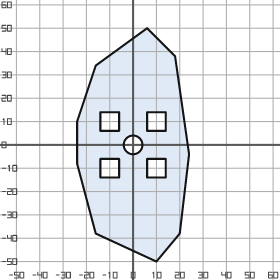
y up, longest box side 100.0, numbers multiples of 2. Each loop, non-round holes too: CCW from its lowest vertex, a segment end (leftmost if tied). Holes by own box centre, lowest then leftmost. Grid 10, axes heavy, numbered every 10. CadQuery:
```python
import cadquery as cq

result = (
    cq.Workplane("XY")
    .moveTo(10.0, -50.0)
    .lineTo(20.0, -38.0)
    .lineTo(24.0, -4.0)
    .lineTo(18.0, 38.0)
    .lineTo(6.0, 50.0)
    .lineTo(-16.0, 34.0)
    .lineTo(-24.0, 10.0)
    .lineTo(-24.0, -8.0)
    .lineTo(-16.0, -38.0)
    .close()
    .moveTo(-14.0, -14.0)
    .lineTo(-6.0, -14.0)
    .lineTo(-6.0, -6.0)
    .lineTo(-14.0, -6.0)
    .close()
    .moveTo(6.0, -14.0)
    .lineTo(14.0, -14.0)
    .lineTo(14.0, -6.0)
    .lineTo(6.0, -6.0)
    .close()
    .moveTo(0.0, 0.0)
    .circle(4.0)
    .moveTo(-14.0, 6.0)
    .lineTo(-6.0, 6.0)
    .lineTo(-6.0, 14.0)
    .lineTo(-14.0, 14.0)
    .close()
    .moveTo(6.0, 6.0)
    .lineTo(14.0, 6.0)
    .lineTo(14.0, 14.0)
    .lineTo(6.0, 14.0)
    .close()
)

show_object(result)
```